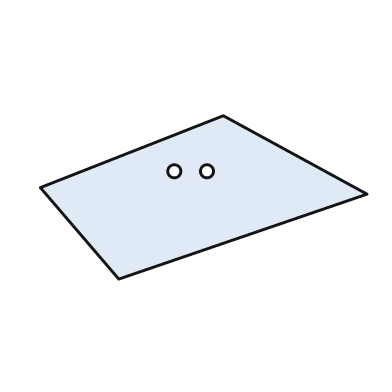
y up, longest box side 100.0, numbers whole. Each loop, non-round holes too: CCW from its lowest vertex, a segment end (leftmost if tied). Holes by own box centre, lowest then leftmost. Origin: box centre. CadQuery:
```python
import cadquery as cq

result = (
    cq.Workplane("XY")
    .moveTo(-26.0, -25.0)
    .lineTo(50.0, 1.0)
    .lineTo(6.0, 25.0)
    .lineTo(-50.0, 3.0)
    .close()
    .moveTo(-9.0, 8.0)
    .circle(2.0)
    .moveTo(1.0, 8.0)
    .circle(2.0)
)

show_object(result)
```